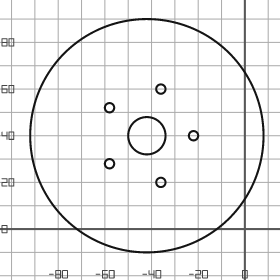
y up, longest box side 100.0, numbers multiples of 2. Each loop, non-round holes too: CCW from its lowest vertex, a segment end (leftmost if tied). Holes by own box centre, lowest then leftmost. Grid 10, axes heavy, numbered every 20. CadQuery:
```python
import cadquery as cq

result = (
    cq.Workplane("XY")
    .moveTo(-42.0, 40.0)
    .circle(50.0)
    .moveTo(-36.0, 20.0)
    .circle(2.0)
    .moveTo(-58.0, 28.0)
    .circle(2.0)
    .moveTo(-42.0, 40.0)
    .circle(8.0)
    .moveTo(-22.0, 40.0)
    .circle(2.0)
    .moveTo(-58.0, 52.0)
    .circle(2.0)
    .moveTo(-36.0, 60.0)
    .circle(2.0)
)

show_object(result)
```